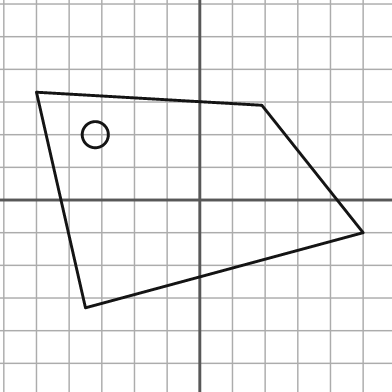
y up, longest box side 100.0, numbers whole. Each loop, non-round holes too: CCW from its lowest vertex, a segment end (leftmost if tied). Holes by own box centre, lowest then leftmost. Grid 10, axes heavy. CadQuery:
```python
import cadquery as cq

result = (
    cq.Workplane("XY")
    .moveTo(-35.0, -33.0)
    .lineTo(50.0, -10.0)
    .lineTo(19.0, 29.0)
    .lineTo(-50.0, 33.0)
    .close()
    .moveTo(-32.0, 20.0)
    .circle(4.0)
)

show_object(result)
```